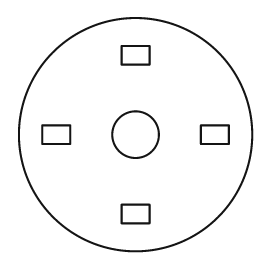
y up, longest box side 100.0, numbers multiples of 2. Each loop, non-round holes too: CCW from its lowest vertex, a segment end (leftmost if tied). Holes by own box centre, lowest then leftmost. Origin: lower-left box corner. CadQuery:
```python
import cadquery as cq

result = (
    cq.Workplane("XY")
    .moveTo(50.0, 50.0)
    .circle(50.0)
    .moveTo(44.0, 12.0)
    .lineTo(56.0, 12.0)
    .lineTo(56.0, 20.0)
    .lineTo(44.0, 20.0)
    .close()
    .moveTo(10.0, 46.0)
    .lineTo(22.0, 46.0)
    .lineTo(22.0, 54.0)
    .lineTo(10.0, 54.0)
    .close()
    .moveTo(50.0, 50.0)
    .circle(10.0)
    .moveTo(78.0, 46.0)
    .lineTo(90.0, 46.0)
    .lineTo(90.0, 54.0)
    .lineTo(78.0, 54.0)
    .close()
    .moveTo(44.0, 80.0)
    .lineTo(56.0, 80.0)
    .lineTo(56.0, 88.0)
    .lineTo(44.0, 88.0)
    .close()
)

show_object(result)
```